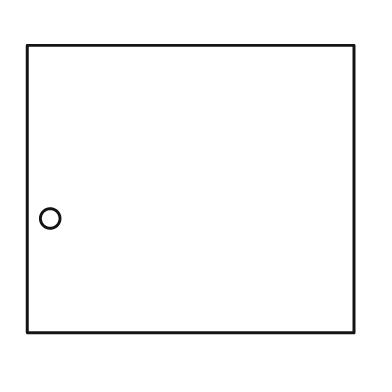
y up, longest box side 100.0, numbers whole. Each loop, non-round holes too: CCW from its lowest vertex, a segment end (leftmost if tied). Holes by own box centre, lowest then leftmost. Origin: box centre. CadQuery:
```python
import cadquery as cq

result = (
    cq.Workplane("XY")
    .moveTo(-50.0, -44.0)
    .lineTo(50.0, -44.0)
    .lineTo(50.0, 44.0)
    .lineTo(-50.0, 44.0)
    .close()
    .moveTo(-43.0, -9.0)
    .circle(3.0)
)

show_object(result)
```